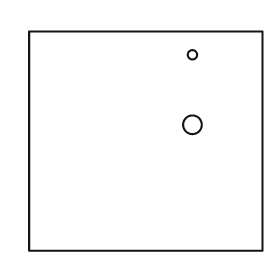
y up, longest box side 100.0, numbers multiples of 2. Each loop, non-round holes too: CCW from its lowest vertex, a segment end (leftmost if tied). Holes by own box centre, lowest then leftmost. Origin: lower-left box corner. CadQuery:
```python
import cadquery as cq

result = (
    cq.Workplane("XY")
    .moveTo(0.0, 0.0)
    .lineTo(100.0, 0.0)
    .lineTo(100.0, 94.0)
    .lineTo(0.0, 94.0)
    .close()
    .moveTo(70.0, 54.0)
    .circle(4.0)
    .moveTo(70.0, 84.0)
    .circle(2.0)
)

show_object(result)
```